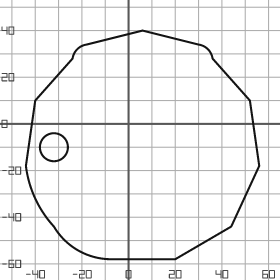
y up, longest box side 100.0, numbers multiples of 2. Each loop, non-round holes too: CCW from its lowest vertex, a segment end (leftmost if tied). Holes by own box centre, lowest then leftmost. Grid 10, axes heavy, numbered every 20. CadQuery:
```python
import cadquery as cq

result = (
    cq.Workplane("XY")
    .moveTo(-8.0, -58.0)
    .lineTo(20.0, -58.0)
    .lineTo(44.0, -44.0)
    .lineTo(56.0, -18.0)
    .lineTo(52.0, 10.0)
    .lineTo(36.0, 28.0)
    .threePointArc((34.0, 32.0), (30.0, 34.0))
    .lineTo(6.0, 40.0)
    .lineTo(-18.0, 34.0)
    .threePointArc((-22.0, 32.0), (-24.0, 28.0))
    .lineTo(-40.0, 10.0)
    .lineTo(-44.0, -18.0)
    .threePointArc((-40.0, -32.0), (-32.0, -44.0))
    .threePointArc((-22.0, -54.0), (-8.0, -58.0))
    .close()
    .moveTo(-32.0, -10.0)
    .circle(6.0)
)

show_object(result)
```